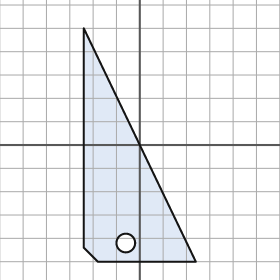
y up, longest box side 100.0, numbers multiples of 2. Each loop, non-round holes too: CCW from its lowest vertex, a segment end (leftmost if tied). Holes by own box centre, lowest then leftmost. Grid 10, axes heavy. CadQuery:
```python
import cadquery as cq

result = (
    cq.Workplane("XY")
    .moveTo(-18.0, -50.0)
    .lineTo(24.0, -50.0)
    .lineTo(-24.0, 50.0)
    .lineTo(-24.0, -44.0)
    .close()
    .moveTo(-6.0, -42.0)
    .circle(4.0)
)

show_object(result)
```